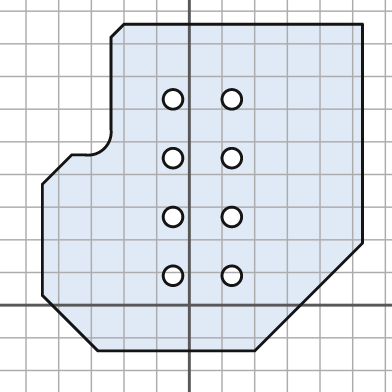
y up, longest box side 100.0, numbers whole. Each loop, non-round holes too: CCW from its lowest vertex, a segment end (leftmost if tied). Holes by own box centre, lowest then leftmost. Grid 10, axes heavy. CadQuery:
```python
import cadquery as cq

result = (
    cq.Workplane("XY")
    .moveTo(-28.0, -14.0)
    .lineTo(20.0, -14.0)
    .lineTo(53.0, 19.0)
    .lineTo(53.0, 86.0)
    .lineTo(-20.0, 86.0)
    .lineTo(-24.0, 82.0)
    .lineTo(-24.0, 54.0)
    .threePointArc((-26.0, 48.0), (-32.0, 46.0))
    .lineTo(-36.0, 46.0)
    .lineTo(-45.0, 37.0)
    .lineTo(-45.0, 3.0)
    .close()
    .moveTo(-5.0, 9.0)
    .circle(3.0)
    .moveTo(13.0, 9.0)
    .circle(3.0)
    .moveTo(-5.0, 27.0)
    .circle(3.0)
    .moveTo(13.0, 27.0)
    .circle(3.0)
    .moveTo(-5.0, 45.0)
    .circle(3.0)
    .moveTo(13.0, 45.0)
    .circle(3.0)
    .moveTo(-5.0, 63.0)
    .circle(3.0)
    .moveTo(13.0, 63.0)
    .circle(3.0)
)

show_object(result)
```